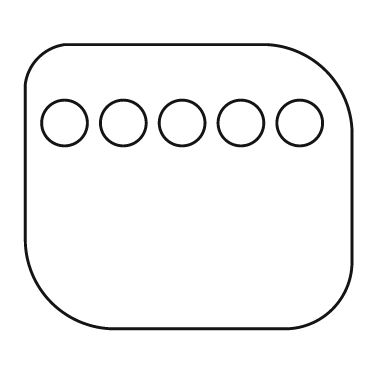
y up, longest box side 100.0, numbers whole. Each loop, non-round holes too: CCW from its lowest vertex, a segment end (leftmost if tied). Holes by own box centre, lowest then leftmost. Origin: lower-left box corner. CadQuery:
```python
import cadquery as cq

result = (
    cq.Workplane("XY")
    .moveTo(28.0, 0.0)
    .lineTo(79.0, 0.0)
    .threePointArc((94.0, 6.0), (100.0, 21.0))
    .lineTo(100.0, 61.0)
    .threePointArc((92.0, 79.0), (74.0, 87.0))
    .lineTo(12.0, 87.0)
    .threePointArc((4.0, 83.0), (0.0, 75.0))
    .lineTo(0.0, 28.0)
    .threePointArc((8.0, 8.0), (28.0, 0.0))
    .close()
    .moveTo(12.0, 63.0)
    .circle(7.0)
    .moveTo(30.0, 63.0)
    .circle(7.0)
    .moveTo(48.0, 63.0)
    .circle(7.0)
    .moveTo(66.0, 63.0)
    .circle(7.0)
    .moveTo(84.0, 63.0)
    .circle(7.0)
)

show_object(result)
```